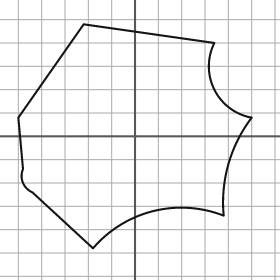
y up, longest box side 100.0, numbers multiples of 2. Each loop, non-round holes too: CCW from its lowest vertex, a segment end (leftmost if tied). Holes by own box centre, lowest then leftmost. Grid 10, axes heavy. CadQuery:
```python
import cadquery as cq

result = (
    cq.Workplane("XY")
    .moveTo(-18.0, -48.0)
    .threePointArc((8.0, -32.0), (38.0, -34.0))
    .threePointArc((40.0, -12.0), (50.0, 8.0))
    .threePointArc((34.0, 20.0), (34.0, 40.0))
    .lineTo(-22.0, 48.0)
    .lineTo(-50.0, 8.0)
    .lineTo(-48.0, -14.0)
    .threePointArc((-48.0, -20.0), (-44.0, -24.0))
    .close()
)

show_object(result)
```